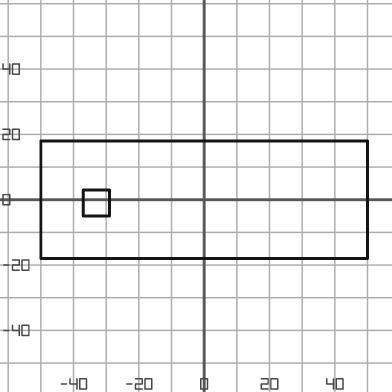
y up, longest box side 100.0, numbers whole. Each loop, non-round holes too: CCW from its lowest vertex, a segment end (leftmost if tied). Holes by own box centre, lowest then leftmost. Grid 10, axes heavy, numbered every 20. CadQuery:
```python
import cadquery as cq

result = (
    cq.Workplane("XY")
    .moveTo(-50.0, -18.0)
    .lineTo(50.0, -18.0)
    .lineTo(50.0, 18.0)
    .lineTo(-50.0, 18.0)
    .close()
    .moveTo(-37.0, -5.0)
    .lineTo(-29.0, -5.0)
    .lineTo(-29.0, 3.0)
    .lineTo(-37.0, 3.0)
    .close()
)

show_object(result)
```